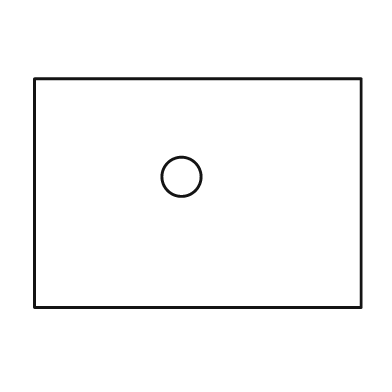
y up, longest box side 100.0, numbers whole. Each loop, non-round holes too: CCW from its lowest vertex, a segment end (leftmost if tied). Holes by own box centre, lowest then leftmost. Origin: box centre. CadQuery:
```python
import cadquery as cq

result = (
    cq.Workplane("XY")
    .moveTo(-50.0, -35.0)
    .lineTo(50.0, -35.0)
    .lineTo(50.0, 35.0)
    .lineTo(-50.0, 35.0)
    .close()
    .moveTo(-5.0, 5.0)
    .circle(6.0)
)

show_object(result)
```